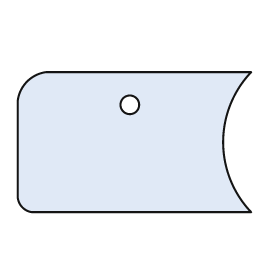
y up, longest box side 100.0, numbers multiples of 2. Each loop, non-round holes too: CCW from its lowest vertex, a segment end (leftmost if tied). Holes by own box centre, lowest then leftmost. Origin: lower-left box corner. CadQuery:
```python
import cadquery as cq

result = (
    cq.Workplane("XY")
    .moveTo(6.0, 0.0)
    .lineTo(100.0, 0.0)
    .threePointArc((88.0, 30.0), (100.0, 60.0))
    .lineTo(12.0, 60.0)
    .threePointArc((4.0, 56.0), (0.0, 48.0))
    .lineTo(0.0, 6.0)
    .threePointArc((2.0, 2.0), (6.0, 0.0))
    .close()
    .moveTo(48.0, 46.0)
    .circle(4.0)
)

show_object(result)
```